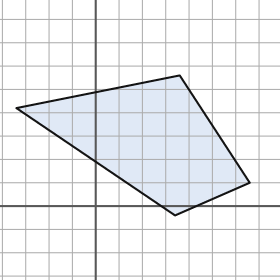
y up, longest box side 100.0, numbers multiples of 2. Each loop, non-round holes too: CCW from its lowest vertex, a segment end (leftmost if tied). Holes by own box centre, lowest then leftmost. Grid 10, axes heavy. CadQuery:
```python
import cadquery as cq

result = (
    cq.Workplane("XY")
    .moveTo(34.0, -4.0)
    .lineTo(66.0, 10.0)
    .lineTo(36.0, 56.0)
    .lineTo(-34.0, 42.0)
    .close()
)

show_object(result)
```